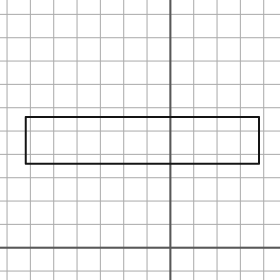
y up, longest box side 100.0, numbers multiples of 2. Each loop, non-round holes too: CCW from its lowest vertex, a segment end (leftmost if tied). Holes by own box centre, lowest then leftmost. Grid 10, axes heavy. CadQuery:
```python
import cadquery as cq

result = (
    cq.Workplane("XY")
    .moveTo(-62.0, 36.0)
    .lineTo(38.0, 36.0)
    .lineTo(38.0, 56.0)
    .lineTo(-62.0, 56.0)
    .close()
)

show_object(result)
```